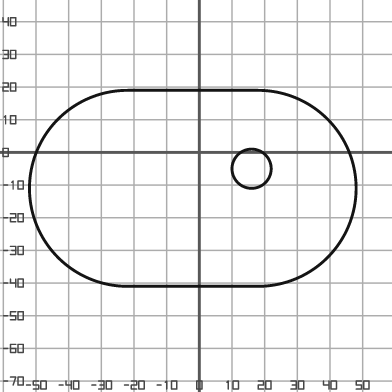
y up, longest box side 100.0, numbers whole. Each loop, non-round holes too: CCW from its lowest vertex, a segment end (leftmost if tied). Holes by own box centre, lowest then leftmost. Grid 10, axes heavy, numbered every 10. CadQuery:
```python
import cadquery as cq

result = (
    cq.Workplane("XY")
    .moveTo(-22.0, -41.0)
    .lineTo(18.0, -41.0)
    .threePointArc((48.0, -11.0), (18.0, 19.0))
    .lineTo(-22.0, 19.0)
    .threePointArc((-52.0, -11.0), (-22.0, -41.0))
    .close()
    .moveTo(16.0, -5.0)
    .circle(6.0)
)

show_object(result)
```